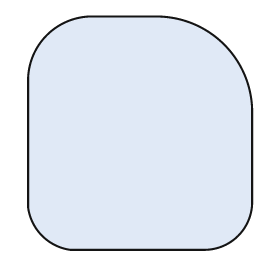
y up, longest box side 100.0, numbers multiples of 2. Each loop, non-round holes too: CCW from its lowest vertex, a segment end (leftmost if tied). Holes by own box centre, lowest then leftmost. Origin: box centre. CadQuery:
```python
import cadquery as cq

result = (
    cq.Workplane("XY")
    .moveTo(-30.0, -50.0)
    .lineTo(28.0, -50.0)
    .threePointArc((42.0, -44.0), (48.0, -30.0))
    .lineTo(48.0, 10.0)
    .threePointArc((36.0, 38.0), (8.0, 50.0))
    .lineTo(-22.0, 50.0)
    .threePointArc((-40.0, 42.0), (-48.0, 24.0))
    .lineTo(-48.0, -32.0)
    .threePointArc((-42.0, -44.0), (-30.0, -50.0))
    .close()
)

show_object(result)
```